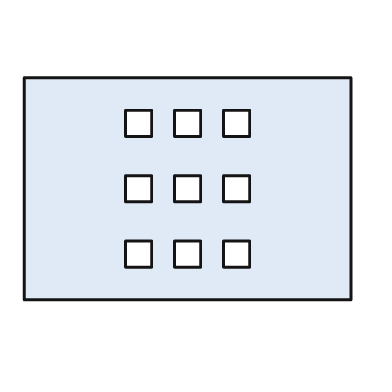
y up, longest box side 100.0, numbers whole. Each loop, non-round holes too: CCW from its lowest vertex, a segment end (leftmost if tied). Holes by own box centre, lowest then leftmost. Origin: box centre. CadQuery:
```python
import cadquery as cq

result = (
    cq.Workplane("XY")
    .moveTo(-50.0, -34.0)
    .lineTo(50.0, -34.0)
    .lineTo(50.0, 34.0)
    .lineTo(-50.0, 34.0)
    .close()
    .moveTo(-19.0, -24.0)
    .lineTo(-11.0, -24.0)
    .lineTo(-11.0, -16.0)
    .lineTo(-19.0, -16.0)
    .close()
    .moveTo(-4.0, -24.0)
    .lineTo(4.0, -24.0)
    .lineTo(4.0, -16.0)
    .lineTo(-4.0, -16.0)
    .close()
    .moveTo(11.0, -24.0)
    .lineTo(19.0, -24.0)
    .lineTo(19.0, -16.0)
    .lineTo(11.0, -16.0)
    .close()
    .moveTo(-19.0, -4.0)
    .lineTo(-11.0, -4.0)
    .lineTo(-11.0, 4.0)
    .lineTo(-19.0, 4.0)
    .close()
    .moveTo(-4.0, -4.0)
    .lineTo(4.0, -4.0)
    .lineTo(4.0, 4.0)
    .lineTo(-4.0, 4.0)
    .close()
    .moveTo(11.0, -4.0)
    .lineTo(19.0, -4.0)
    .lineTo(19.0, 4.0)
    .lineTo(11.0, 4.0)
    .close()
    .moveTo(-19.0, 16.0)
    .lineTo(-11.0, 16.0)
    .lineTo(-11.0, 24.0)
    .lineTo(-19.0, 24.0)
    .close()
    .moveTo(-4.0, 16.0)
    .lineTo(4.0, 16.0)
    .lineTo(4.0, 24.0)
    .lineTo(-4.0, 24.0)
    .close()
    .moveTo(11.0, 16.0)
    .lineTo(19.0, 16.0)
    .lineTo(19.0, 24.0)
    .lineTo(11.0, 24.0)
    .close()
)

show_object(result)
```